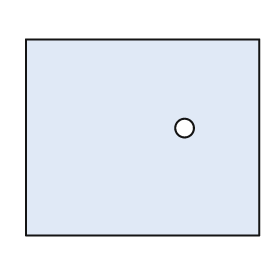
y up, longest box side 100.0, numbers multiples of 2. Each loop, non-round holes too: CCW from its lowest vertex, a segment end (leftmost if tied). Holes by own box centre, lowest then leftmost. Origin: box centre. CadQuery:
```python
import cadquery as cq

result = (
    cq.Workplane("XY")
    .moveTo(-50.0, -42.0)
    .lineTo(50.0, -42.0)
    .lineTo(50.0, 42.0)
    .lineTo(-50.0, 42.0)
    .close()
    .moveTo(18.0, 4.0)
    .circle(4.0)
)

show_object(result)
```